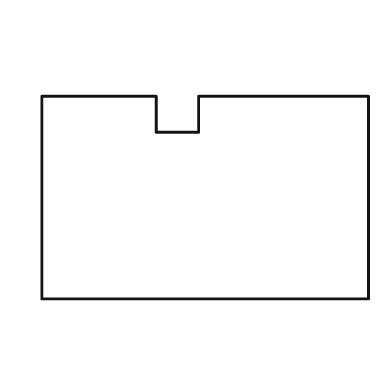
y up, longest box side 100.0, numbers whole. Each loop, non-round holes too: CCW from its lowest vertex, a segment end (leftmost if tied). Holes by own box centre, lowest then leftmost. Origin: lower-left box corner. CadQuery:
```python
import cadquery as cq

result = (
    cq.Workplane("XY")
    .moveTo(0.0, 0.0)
    .lineTo(100.0, 0.0)
    .lineTo(100.0, 62.0)
    .lineTo(48.0, 62.0)
    .lineTo(48.0, 51.0)
    .lineTo(35.0, 51.0)
    .lineTo(35.0, 62.0)
    .lineTo(0.0, 62.0)
    .close()
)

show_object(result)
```